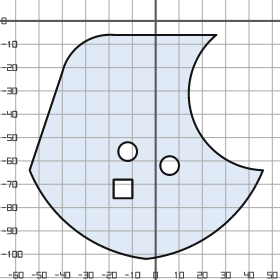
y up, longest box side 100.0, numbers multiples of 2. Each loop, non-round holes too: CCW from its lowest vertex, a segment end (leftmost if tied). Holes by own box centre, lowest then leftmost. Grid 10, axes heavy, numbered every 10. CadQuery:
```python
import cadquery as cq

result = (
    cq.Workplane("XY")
    .moveTo(-4.0, -102.0)
    .threePointArc((26.0, -90.0), (46.0, -64.0))
    .threePointArc((16.0, -42.0), (26.0, -6.0))
    .lineTo(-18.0, -6.0)
    .threePointArc((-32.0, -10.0), (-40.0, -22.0))
    .lineTo(-54.0, -64.0)
    .threePointArc((-34.0, -90.0), (-4.0, -102.0))
    .close()
    .moveTo(-18.0, -76.0)
    .lineTo(-10.0, -76.0)
    .lineTo(-10.0, -68.0)
    .lineTo(-18.0, -68.0)
    .close()
    .moveTo(6.0, -62.0)
    .circle(4.0)
    .moveTo(-12.0, -56.0)
    .circle(4.0)
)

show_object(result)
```